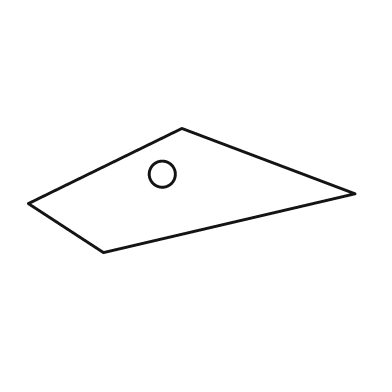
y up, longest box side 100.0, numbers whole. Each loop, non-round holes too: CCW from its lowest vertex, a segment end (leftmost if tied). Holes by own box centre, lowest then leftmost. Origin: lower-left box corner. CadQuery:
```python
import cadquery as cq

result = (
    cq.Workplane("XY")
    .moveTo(23.0, 0.0)
    .lineTo(100.0, 18.0)
    .lineTo(47.0, 38.0)
    .lineTo(0.0, 15.0)
    .close()
    .moveTo(41.0, 24.0)
    .circle(4.0)
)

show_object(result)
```